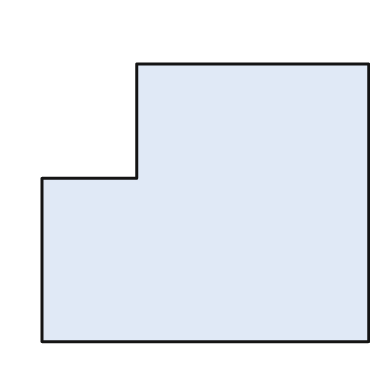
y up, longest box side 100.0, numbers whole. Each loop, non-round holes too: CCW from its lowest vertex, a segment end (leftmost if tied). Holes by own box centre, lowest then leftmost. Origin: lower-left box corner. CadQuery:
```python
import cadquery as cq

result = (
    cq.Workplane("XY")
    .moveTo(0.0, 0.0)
    .lineTo(100.0, 0.0)
    .lineTo(100.0, 85.0)
    .lineTo(29.0, 85.0)
    .lineTo(29.0, 50.0)
    .lineTo(0.0, 50.0)
    .close()
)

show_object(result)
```